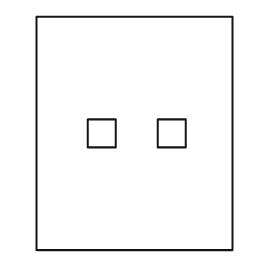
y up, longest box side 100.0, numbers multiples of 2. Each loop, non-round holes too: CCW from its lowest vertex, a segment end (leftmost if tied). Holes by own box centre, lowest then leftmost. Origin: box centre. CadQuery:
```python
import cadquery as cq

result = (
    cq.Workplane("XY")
    .moveTo(-42.0, -50.0)
    .lineTo(42.0, -50.0)
    .lineTo(42.0, 50.0)
    .lineTo(-42.0, 50.0)
    .close()
    .moveTo(-20.0, -6.0)
    .lineTo(-8.0, -6.0)
    .lineTo(-8.0, 6.0)
    .lineTo(-20.0, 6.0)
    .close()
    .moveTo(10.0, -6.0)
    .lineTo(22.0, -6.0)
    .lineTo(22.0, 6.0)
    .lineTo(10.0, 6.0)
    .close()
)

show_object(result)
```